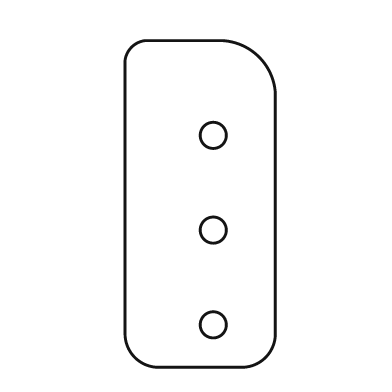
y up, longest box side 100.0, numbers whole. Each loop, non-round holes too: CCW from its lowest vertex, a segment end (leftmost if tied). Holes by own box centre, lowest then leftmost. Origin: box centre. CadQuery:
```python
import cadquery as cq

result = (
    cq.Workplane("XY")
    .moveTo(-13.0, -50.0)
    .lineTo(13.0, -50.0)
    .threePointArc((20.0, -47.0), (23.0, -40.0))
    .lineTo(23.0, 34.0)
    .threePointArc((18.0, 45.0), (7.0, 50.0))
    .lineTo(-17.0, 50.0)
    .threePointArc((-21.0, 48.0), (-23.0, 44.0))
    .lineTo(-23.0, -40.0)
    .threePointArc((-20.0, -47.0), (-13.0, -50.0))
    .close()
    .moveTo(4.0, -37.0)
    .circle(4.0)
    .moveTo(4.0, -8.0)
    .circle(4.0)
    .moveTo(4.0, 21.0)
    .circle(4.0)
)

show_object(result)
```